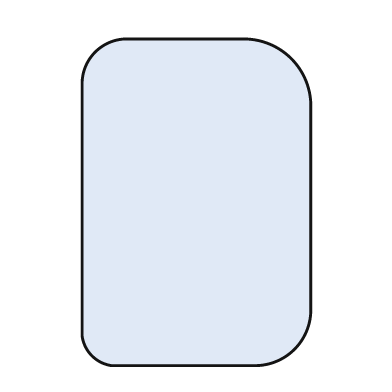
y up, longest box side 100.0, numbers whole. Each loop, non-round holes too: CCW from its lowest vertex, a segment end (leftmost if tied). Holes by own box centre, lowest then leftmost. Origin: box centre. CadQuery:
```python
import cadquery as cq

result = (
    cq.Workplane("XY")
    .moveTo(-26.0, -50.0)
    .lineTo(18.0, -50.0)
    .threePointArc((30.0, -45.0), (35.0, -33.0))
    .lineTo(35.0, 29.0)
    .threePointArc((29.0, 44.0), (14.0, 50.0))
    .lineTo(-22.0, 50.0)
    .threePointArc((-31.0, 46.0), (-35.0, 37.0))
    .lineTo(-35.0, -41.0)
    .threePointArc((-32.0, -47.0), (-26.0, -50.0))
    .close()
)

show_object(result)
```